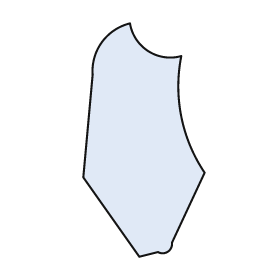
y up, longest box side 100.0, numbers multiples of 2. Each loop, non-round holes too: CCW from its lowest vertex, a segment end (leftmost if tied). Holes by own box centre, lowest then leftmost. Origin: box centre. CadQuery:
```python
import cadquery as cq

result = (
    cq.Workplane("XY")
    .moveTo(-2.0, -50.0)
    .lineTo(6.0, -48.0)
    .threePointArc((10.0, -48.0), (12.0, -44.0))
    .lineTo(26.0, -14.0)
    .threePointArc((16.0, 10.0), (16.0, 36.0))
    .threePointArc((2.0, 38.0), (-6.0, 50.0))
    .threePointArc((-18.0, 42.0), (-22.0, 28.0))
    .lineTo(-26.0, -16.0)
    .close()
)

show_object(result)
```